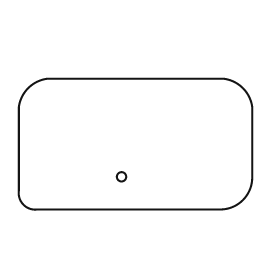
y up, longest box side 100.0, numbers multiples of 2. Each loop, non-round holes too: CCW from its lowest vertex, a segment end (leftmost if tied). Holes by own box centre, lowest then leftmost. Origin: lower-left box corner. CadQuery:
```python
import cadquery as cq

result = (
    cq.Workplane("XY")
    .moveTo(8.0, 0.0)
    .lineTo(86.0, 0.0)
    .threePointArc((96.0, 4.0), (100.0, 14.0))
    .lineTo(100.0, 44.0)
    .threePointArc((96.0, 52.0), (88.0, 56.0))
    .lineTo(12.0, 56.0)
    .threePointArc((4.0, 52.0), (0.0, 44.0))
    .lineTo(0.0, 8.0)
    .threePointArc((2.0, 2.0), (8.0, 0.0))
    .close()
    .moveTo(44.0, 14.0)
    .circle(2.0)
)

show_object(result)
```